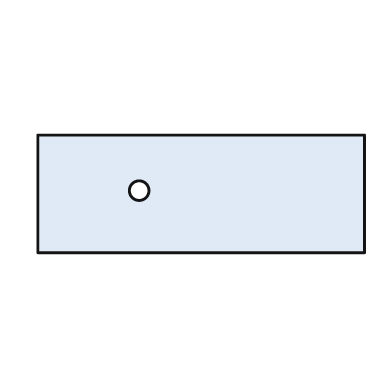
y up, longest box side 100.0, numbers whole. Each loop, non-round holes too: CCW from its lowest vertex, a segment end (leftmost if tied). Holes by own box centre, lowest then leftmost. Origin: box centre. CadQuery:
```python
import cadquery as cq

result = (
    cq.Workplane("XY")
    .moveTo(-50.0, -18.0)
    .lineTo(50.0, -18.0)
    .lineTo(50.0, 18.0)
    .lineTo(-50.0, 18.0)
    .close()
    .moveTo(-19.0, 1.0)
    .circle(3.0)
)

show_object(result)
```